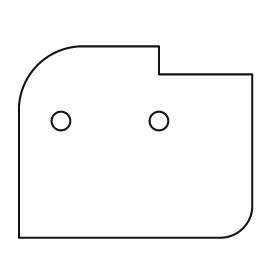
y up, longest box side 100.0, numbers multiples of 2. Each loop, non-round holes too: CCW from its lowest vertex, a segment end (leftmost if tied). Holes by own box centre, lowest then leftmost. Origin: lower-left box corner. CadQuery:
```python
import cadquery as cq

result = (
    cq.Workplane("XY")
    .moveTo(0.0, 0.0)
    .lineTo(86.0, 0.0)
    .threePointArc((96.0, 4.0), (100.0, 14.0))
    .lineTo(100.0, 70.0)
    .lineTo(60.0, 70.0)
    .lineTo(60.0, 82.0)
    .lineTo(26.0, 82.0)
    .threePointArc((8.0, 74.0), (0.0, 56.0))
    .close()
    .moveTo(18.0, 50.0)
    .circle(4.0)
    .moveTo(60.0, 50.0)
    .circle(4.0)
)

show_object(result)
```